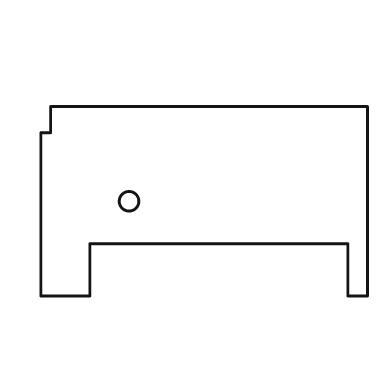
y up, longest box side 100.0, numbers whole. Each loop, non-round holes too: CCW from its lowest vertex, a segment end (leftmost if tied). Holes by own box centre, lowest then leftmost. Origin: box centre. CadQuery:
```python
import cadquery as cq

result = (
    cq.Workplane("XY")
    .moveTo(-50.0, -29.0)
    .lineTo(-35.0, -29.0)
    .lineTo(-35.0, -13.0)
    .lineTo(44.0, -13.0)
    .lineTo(44.0, -29.0)
    .lineTo(50.0, -29.0)
    .lineTo(50.0, 29.0)
    .lineTo(-47.0, 29.0)
    .lineTo(-47.0, 21.0)
    .lineTo(-50.0, 21.0)
    .close()
    .moveTo(-23.0, 0.0)
    .circle(3.0)
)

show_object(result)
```